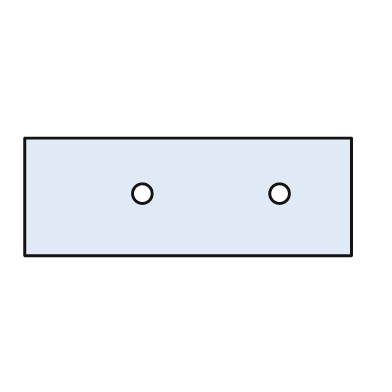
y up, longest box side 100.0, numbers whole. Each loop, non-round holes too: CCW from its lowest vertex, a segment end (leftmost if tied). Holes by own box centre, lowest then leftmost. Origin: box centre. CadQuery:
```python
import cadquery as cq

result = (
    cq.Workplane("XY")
    .moveTo(-50.0, -18.0)
    .lineTo(50.0, -18.0)
    .lineTo(50.0, 18.0)
    .lineTo(-50.0, 18.0)
    .close()
    .moveTo(-14.0, 1.0)
    .circle(3.0)
    .moveTo(28.0, 1.0)
    .circle(3.0)
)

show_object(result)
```